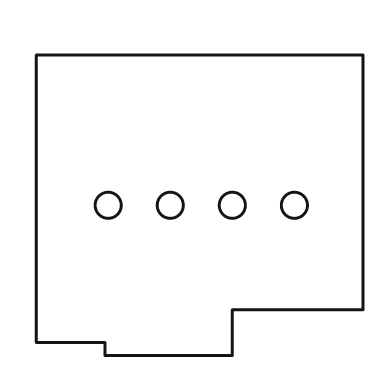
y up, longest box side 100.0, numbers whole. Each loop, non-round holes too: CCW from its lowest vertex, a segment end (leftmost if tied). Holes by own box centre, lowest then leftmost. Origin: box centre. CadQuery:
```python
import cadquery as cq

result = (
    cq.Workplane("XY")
    .moveTo(-29.0, -46.0)
    .lineTo(10.0, -46.0)
    .lineTo(10.0, -32.0)
    .lineTo(50.0, -32.0)
    .lineTo(50.0, 46.0)
    .lineTo(-50.0, 46.0)
    .lineTo(-50.0, -42.0)
    .lineTo(-29.0, -42.0)
    .close()
    .moveTo(-28.0, 0.0)
    .circle(4.0)
    .moveTo(-9.0, 0.0)
    .circle(4.0)
    .moveTo(10.0, 0.0)
    .circle(4.0)
    .moveTo(29.0, 0.0)
    .circle(4.0)
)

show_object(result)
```